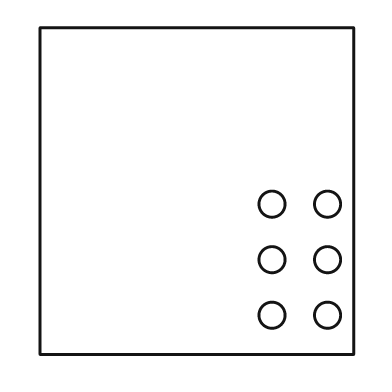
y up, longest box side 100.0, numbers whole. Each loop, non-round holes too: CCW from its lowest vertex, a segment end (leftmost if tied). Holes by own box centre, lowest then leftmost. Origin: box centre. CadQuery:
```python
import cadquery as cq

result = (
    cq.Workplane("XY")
    .moveTo(-48.0, -50.0)
    .lineTo(48.0, -50.0)
    .lineTo(48.0, 50.0)
    .lineTo(-48.0, 50.0)
    .close()
    .moveTo(23.0, -38.0)
    .circle(4.0)
    .moveTo(40.0, -38.0)
    .circle(4.0)
    .moveTo(23.0, -21.0)
    .circle(4.0)
    .moveTo(40.0, -21.0)
    .circle(4.0)
    .moveTo(23.0, -4.0)
    .circle(4.0)
    .moveTo(40.0, -4.0)
    .circle(4.0)
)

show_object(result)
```